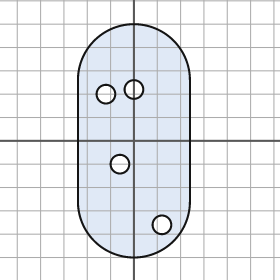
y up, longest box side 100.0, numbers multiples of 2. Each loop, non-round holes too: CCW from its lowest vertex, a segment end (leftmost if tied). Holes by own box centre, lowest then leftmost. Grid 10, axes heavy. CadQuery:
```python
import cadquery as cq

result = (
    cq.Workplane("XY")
    .moveTo(-24.0, -26.0)
    .threePointArc((0.0, -50.0), (24.0, -26.0))
    .lineTo(24.0, 26.0)
    .threePointArc((0.0, 50.0), (-24.0, 26.0))
    .close()
    .moveTo(12.0, -36.0)
    .circle(4.0)
    .moveTo(-6.0, -10.0)
    .circle(4.0)
    .moveTo(-12.0, 20.0)
    .circle(4.0)
    .moveTo(0.0, 22.0)
    .circle(4.0)
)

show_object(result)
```